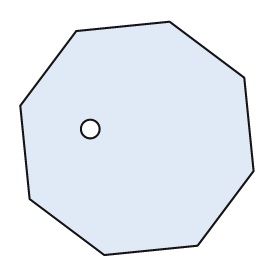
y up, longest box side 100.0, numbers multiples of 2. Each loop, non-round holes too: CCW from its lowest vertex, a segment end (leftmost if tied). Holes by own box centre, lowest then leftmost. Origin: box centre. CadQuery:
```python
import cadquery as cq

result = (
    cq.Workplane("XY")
    .moveTo(-14.0, -50.0)
    .lineTo(26.0, -46.0)
    .lineTo(50.0, -14.0)
    .lineTo(46.0, 26.0)
    .lineTo(14.0, 50.0)
    .lineTo(-26.0, 46.0)
    .lineTo(-50.0, 14.0)
    .lineTo(-46.0, -26.0)
    .close()
    .moveTo(-20.0, 4.0)
    .circle(4.0)
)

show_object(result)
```